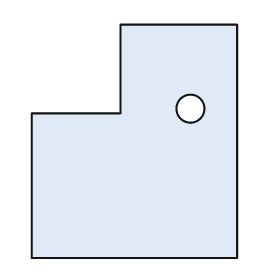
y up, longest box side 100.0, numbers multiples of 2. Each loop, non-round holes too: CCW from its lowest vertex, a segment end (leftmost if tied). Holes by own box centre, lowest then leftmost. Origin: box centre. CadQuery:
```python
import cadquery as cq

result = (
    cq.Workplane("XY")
    .moveTo(-44.0, -50.0)
    .lineTo(44.0, -50.0)
    .lineTo(44.0, 50.0)
    .lineTo(-6.0, 50.0)
    .lineTo(-6.0, 12.0)
    .lineTo(-44.0, 12.0)
    .close()
    .moveTo(24.0, 14.0)
    .circle(6.0)
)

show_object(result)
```